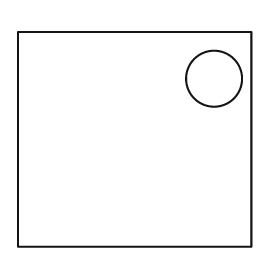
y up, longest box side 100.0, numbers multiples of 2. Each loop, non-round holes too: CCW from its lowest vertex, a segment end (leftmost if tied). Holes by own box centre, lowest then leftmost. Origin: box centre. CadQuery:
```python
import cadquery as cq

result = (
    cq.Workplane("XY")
    .moveTo(-50.0, -46.0)
    .lineTo(50.0, -46.0)
    .lineTo(50.0, 46.0)
    .lineTo(-50.0, 46.0)
    .close()
    .moveTo(34.0, 26.0)
    .circle(12.0)
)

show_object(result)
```